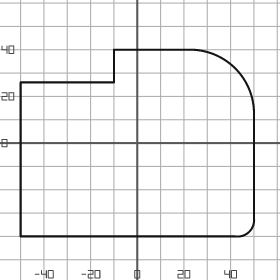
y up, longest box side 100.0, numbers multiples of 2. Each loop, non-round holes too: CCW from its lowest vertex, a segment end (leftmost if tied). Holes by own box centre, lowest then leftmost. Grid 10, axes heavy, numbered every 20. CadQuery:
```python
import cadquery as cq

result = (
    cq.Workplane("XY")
    .moveTo(-50.0, -40.0)
    .lineTo(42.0, -40.0)
    .threePointArc((48.0, -38.0), (50.0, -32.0))
    .lineTo(50.0, 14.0)
    .threePointArc((42.0, 32.0), (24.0, 40.0))
    .lineTo(-10.0, 40.0)
    .lineTo(-10.0, 26.0)
    .lineTo(-50.0, 26.0)
    .close()
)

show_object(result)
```